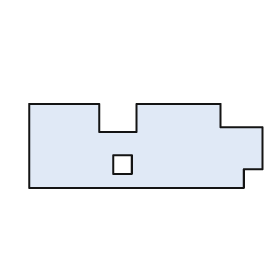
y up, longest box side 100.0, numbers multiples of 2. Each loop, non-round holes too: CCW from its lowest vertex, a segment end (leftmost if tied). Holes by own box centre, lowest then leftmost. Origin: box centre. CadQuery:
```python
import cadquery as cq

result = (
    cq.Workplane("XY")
    .moveTo(-50.0, -18.0)
    .lineTo(42.0, -18.0)
    .lineTo(42.0, -10.0)
    .lineTo(50.0, -10.0)
    .lineTo(50.0, 8.0)
    .lineTo(32.0, 8.0)
    .lineTo(32.0, 18.0)
    .lineTo(-4.0, 18.0)
    .lineTo(-4.0, 6.0)
    .lineTo(-20.0, 6.0)
    .lineTo(-20.0, 18.0)
    .lineTo(-50.0, 18.0)
    .close()
    .moveTo(-14.0, -12.0)
    .lineTo(-6.0, -12.0)
    .lineTo(-6.0, -4.0)
    .lineTo(-14.0, -4.0)
    .close()
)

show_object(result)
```